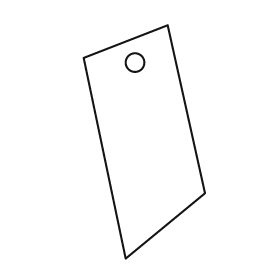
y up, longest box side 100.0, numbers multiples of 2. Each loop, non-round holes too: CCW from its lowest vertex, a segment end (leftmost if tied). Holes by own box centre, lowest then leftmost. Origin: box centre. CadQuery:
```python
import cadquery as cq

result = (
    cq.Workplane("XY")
    .moveTo(-8.0, -50.0)
    .lineTo(26.0, -22.0)
    .lineTo(10.0, 50.0)
    .lineTo(-26.0, 36.0)
    .close()
    .moveTo(-4.0, 34.0)
    .circle(4.0)
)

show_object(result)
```